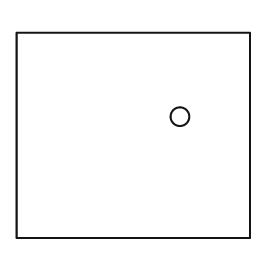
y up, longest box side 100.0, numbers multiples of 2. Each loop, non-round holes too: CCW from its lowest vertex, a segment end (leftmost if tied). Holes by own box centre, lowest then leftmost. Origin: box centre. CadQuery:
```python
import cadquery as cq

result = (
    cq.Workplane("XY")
    .moveTo(-50.0, -44.0)
    .lineTo(50.0, -44.0)
    .lineTo(50.0, 44.0)
    .lineTo(-50.0, 44.0)
    .close()
    .moveTo(20.0, 8.0)
    .circle(4.0)
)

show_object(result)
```